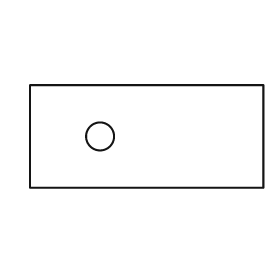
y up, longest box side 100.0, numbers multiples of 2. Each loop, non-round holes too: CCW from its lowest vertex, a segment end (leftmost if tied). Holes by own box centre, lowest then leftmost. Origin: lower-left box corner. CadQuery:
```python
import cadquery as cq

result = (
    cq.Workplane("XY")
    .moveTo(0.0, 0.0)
    .lineTo(100.0, 0.0)
    .lineTo(100.0, 44.0)
    .lineTo(0.0, 44.0)
    .close()
    .moveTo(30.0, 22.0)
    .circle(6.0)
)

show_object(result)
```